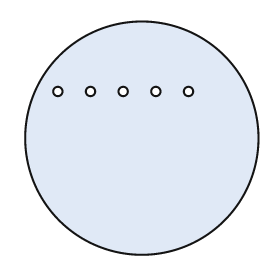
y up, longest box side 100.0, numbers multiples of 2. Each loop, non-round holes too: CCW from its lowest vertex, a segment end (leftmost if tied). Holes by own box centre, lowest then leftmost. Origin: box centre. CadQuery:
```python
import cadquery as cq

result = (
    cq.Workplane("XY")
    .moveTo(0.0, 0.0)
    .circle(50.0)
    .moveTo(-36.0, 20.0)
    .circle(2.0)
    .moveTo(-22.0, 20.0)
    .circle(2.0)
    .moveTo(-8.0, 20.0)
    .circle(2.0)
    .moveTo(6.0, 20.0)
    .circle(2.0)
    .moveTo(20.0, 20.0)
    .circle(2.0)
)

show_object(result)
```